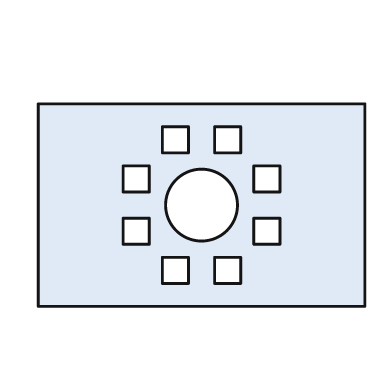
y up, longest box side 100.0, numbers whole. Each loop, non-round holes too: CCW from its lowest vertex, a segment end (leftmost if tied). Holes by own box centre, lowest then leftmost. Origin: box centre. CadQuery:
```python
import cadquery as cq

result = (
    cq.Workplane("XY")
    .moveTo(-50.0, -31.0)
    .lineTo(50.0, -31.0)
    .lineTo(50.0, 31.0)
    .lineTo(-50.0, 31.0)
    .close()
    .moveTo(-12.0, -24.0)
    .lineTo(-4.0, -24.0)
    .lineTo(-4.0, -16.0)
    .lineTo(-12.0, -16.0)
    .close()
    .moveTo(4.0, -24.0)
    .lineTo(12.0, -24.0)
    .lineTo(12.0, -16.0)
    .lineTo(4.0, -16.0)
    .close()
    .moveTo(-24.0, -12.0)
    .lineTo(-16.0, -12.0)
    .lineTo(-16.0, -4.0)
    .lineTo(-24.0, -4.0)
    .close()
    .moveTo(16.0, -12.0)
    .lineTo(24.0, -12.0)
    .lineTo(24.0, -4.0)
    .lineTo(16.0, -4.0)
    .close()
    .moveTo(0.0, 0.0)
    .circle(11.0)
    .moveTo(-24.0, 4.0)
    .lineTo(-16.0, 4.0)
    .lineTo(-16.0, 12.0)
    .lineTo(-24.0, 12.0)
    .close()
    .moveTo(16.0, 4.0)
    .lineTo(24.0, 4.0)
    .lineTo(24.0, 12.0)
    .lineTo(16.0, 12.0)
    .close()
    .moveTo(-12.0, 16.0)
    .lineTo(-4.0, 16.0)
    .lineTo(-4.0, 24.0)
    .lineTo(-12.0, 24.0)
    .close()
    .moveTo(4.0, 16.0)
    .lineTo(12.0, 16.0)
    .lineTo(12.0, 24.0)
    .lineTo(4.0, 24.0)
    .close()
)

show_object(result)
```